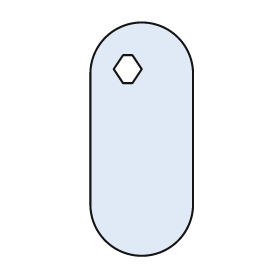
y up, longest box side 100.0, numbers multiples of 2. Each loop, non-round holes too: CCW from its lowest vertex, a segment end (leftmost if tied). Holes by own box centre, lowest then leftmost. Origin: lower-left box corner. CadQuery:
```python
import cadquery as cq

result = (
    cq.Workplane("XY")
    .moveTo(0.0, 22.0)
    .threePointArc((22.0, 0.0), (44.0, 22.0))
    .lineTo(44.0, 78.0)
    .threePointArc((22.0, 100.0), (0.0, 78.0))
    .close()
    .moveTo(14.0, 74.0)
    .lineTo(18.0, 74.0)
    .lineTo(22.0, 80.0)
    .lineTo(18.0, 86.0)
    .lineTo(14.0, 86.0)
    .lineTo(10.0, 80.0)
    .close()
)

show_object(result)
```